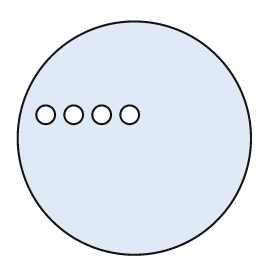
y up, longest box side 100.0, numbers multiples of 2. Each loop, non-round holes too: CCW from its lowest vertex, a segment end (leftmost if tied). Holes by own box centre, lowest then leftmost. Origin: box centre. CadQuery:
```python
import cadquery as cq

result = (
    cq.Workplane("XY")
    .moveTo(0.0, 0.0)
    .circle(50.0)
    .moveTo(-38.0, 10.0)
    .circle(4.0)
    .moveTo(-26.0, 10.0)
    .circle(4.0)
    .moveTo(-14.0, 10.0)
    .circle(4.0)
    .moveTo(-2.0, 10.0)
    .circle(4.0)
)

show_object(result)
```